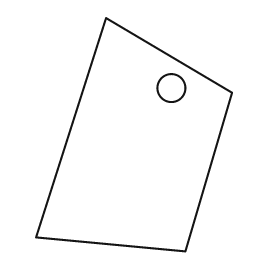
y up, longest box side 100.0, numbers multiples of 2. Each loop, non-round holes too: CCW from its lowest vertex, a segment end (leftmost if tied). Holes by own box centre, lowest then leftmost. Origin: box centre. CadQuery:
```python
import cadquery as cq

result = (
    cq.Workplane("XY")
    .moveTo(22.0, -50.0)
    .lineTo(42.0, 18.0)
    .lineTo(-12.0, 50.0)
    .lineTo(-42.0, -44.0)
    .close()
    .moveTo(16.0, 20.0)
    .circle(6.0)
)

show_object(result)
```